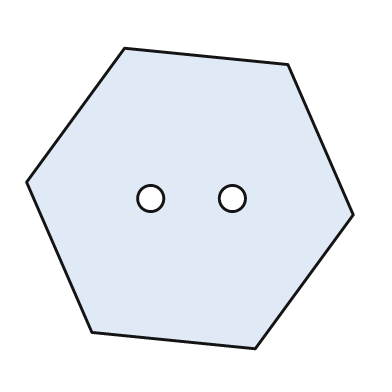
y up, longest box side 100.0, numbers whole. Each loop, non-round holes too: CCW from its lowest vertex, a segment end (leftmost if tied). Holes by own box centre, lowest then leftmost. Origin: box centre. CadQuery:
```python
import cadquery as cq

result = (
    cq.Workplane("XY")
    .moveTo(20.0, -46.0)
    .lineTo(50.0, -5.0)
    .lineTo(30.0, 41.0)
    .lineTo(-20.0, 46.0)
    .lineTo(-50.0, 5.0)
    .lineTo(-30.0, -41.0)
    .close()
    .moveTo(-12.0, 0.0)
    .circle(4.0)
    .moveTo(13.0, 0.0)
    .circle(4.0)
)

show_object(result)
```